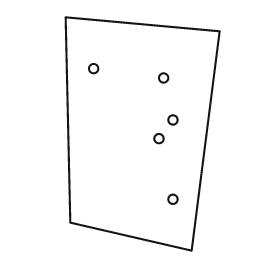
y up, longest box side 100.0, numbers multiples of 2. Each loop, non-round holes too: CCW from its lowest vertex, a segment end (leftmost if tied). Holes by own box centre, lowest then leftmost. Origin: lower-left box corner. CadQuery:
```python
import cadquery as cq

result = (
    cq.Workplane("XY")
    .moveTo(54.0, 0.0)
    .lineTo(66.0, 94.0)
    .lineTo(0.0, 100.0)
    .lineTo(2.0, 12.0)
    .close()
    .moveTo(46.0, 22.0)
    .circle(2.0)
    .moveTo(40.0, 48.0)
    .circle(2.0)
    .moveTo(46.0, 56.0)
    .circle(2.0)
    .moveTo(42.0, 74.0)
    .circle(2.0)
    .moveTo(12.0, 78.0)
    .circle(2.0)
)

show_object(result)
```